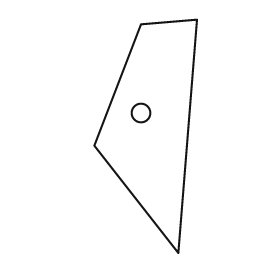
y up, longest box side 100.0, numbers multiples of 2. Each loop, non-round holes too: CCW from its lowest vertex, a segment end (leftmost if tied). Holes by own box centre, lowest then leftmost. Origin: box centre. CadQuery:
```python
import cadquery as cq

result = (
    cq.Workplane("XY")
    .moveTo(14.0, -50.0)
    .lineTo(22.0, 50.0)
    .lineTo(-2.0, 48.0)
    .lineTo(-22.0, -4.0)
    .close()
    .moveTo(-2.0, 10.0)
    .circle(4.0)
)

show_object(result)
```